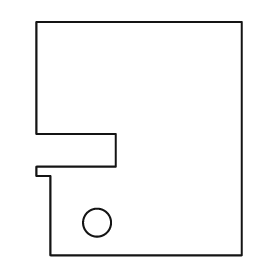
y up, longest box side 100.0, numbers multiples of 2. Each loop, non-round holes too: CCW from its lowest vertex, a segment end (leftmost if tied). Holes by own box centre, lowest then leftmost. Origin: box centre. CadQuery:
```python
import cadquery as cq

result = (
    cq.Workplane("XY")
    .moveTo(-38.0, -50.0)
    .lineTo(44.0, -50.0)
    .lineTo(44.0, 50.0)
    .lineTo(-44.0, 50.0)
    .lineTo(-44.0, 2.0)
    .lineTo(-10.0, 2.0)
    .lineTo(-10.0, -12.0)
    .lineTo(-44.0, -12.0)
    .lineTo(-44.0, -16.0)
    .lineTo(-38.0, -16.0)
    .close()
    .moveTo(-18.0, -36.0)
    .circle(6.0)
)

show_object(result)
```